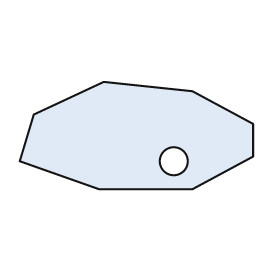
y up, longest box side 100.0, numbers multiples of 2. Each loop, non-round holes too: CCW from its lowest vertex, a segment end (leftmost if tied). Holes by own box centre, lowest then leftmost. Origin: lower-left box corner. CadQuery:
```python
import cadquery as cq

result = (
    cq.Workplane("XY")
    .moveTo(34.0, 0.0)
    .lineTo(74.0, 0.0)
    .lineTo(100.0, 14.0)
    .lineTo(100.0, 28.0)
    .lineTo(74.0, 42.0)
    .lineTo(36.0, 46.0)
    .lineTo(6.0, 32.0)
    .lineTo(0.0, 12.0)
    .close()
    .moveTo(66.0, 12.0)
    .circle(6.0)
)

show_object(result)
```